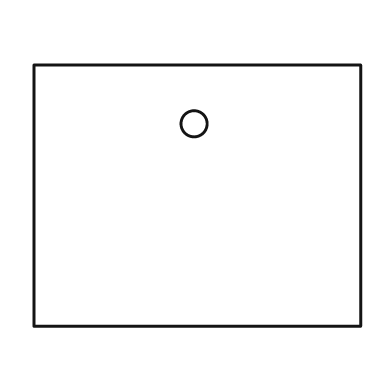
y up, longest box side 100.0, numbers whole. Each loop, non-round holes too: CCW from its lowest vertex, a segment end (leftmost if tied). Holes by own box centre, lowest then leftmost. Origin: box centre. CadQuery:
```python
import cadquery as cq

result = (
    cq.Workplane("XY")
    .moveTo(-50.0, -40.0)
    .lineTo(50.0, -40.0)
    .lineTo(50.0, 40.0)
    .lineTo(-50.0, 40.0)
    .close()
    .moveTo(-1.0, 22.0)
    .circle(4.0)
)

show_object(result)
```